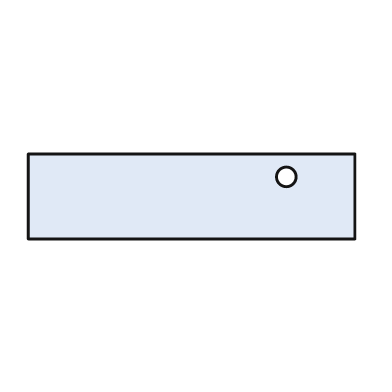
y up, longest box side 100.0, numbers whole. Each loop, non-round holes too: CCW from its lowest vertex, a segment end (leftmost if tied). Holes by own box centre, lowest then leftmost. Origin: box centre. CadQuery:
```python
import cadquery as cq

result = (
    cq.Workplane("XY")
    .moveTo(-50.0, -13.0)
    .lineTo(50.0, -13.0)
    .lineTo(50.0, 13.0)
    .lineTo(-50.0, 13.0)
    .close()
    .moveTo(29.0, 6.0)
    .circle(3.0)
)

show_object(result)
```